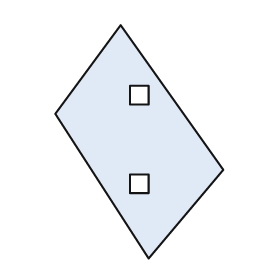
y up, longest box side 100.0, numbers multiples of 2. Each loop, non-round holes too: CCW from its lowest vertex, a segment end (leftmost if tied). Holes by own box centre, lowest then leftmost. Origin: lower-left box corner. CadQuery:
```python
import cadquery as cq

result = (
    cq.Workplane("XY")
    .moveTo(40.0, 0.0)
    .lineTo(72.0, 38.0)
    .lineTo(28.0, 100.0)
    .lineTo(0.0, 62.0)
    .close()
    .moveTo(32.0, 28.0)
    .lineTo(40.0, 28.0)
    .lineTo(40.0, 36.0)
    .lineTo(32.0, 36.0)
    .close()
    .moveTo(32.0, 66.0)
    .lineTo(40.0, 66.0)
    .lineTo(40.0, 74.0)
    .lineTo(32.0, 74.0)
    .close()
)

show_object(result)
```